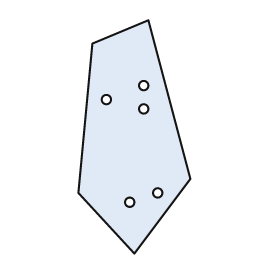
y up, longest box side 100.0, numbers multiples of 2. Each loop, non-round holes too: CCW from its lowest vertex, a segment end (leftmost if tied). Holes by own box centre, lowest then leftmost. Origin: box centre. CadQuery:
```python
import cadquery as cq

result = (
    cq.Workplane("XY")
    .moveTo(0.0, -50.0)
    .lineTo(24.0, -18.0)
    .lineTo(6.0, 50.0)
    .lineTo(-18.0, 40.0)
    .lineTo(-24.0, -24.0)
    .close()
    .moveTo(-2.0, -28.0)
    .circle(2.0)
    .moveTo(10.0, -24.0)
    .circle(2.0)
    .moveTo(4.0, 12.0)
    .circle(2.0)
    .moveTo(-12.0, 16.0)
    .circle(2.0)
    .moveTo(4.0, 22.0)
    .circle(2.0)
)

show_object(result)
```